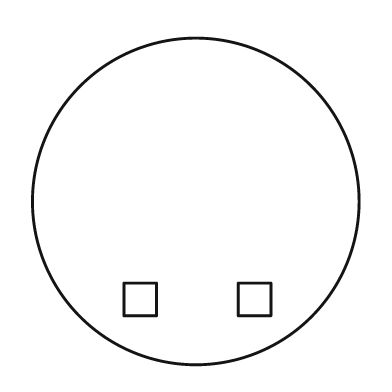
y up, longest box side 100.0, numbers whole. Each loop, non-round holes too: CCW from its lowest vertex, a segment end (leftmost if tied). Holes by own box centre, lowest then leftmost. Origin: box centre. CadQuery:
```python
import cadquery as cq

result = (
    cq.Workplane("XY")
    .moveTo(0.0, 0.0)
    .circle(50.0)
    .moveTo(-22.0, -35.0)
    .lineTo(-12.0, -35.0)
    .lineTo(-12.0, -25.0)
    .lineTo(-22.0, -25.0)
    .close()
    .moveTo(13.0, -35.0)
    .lineTo(23.0, -35.0)
    .lineTo(23.0, -25.0)
    .lineTo(13.0, -25.0)
    .close()
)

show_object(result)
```